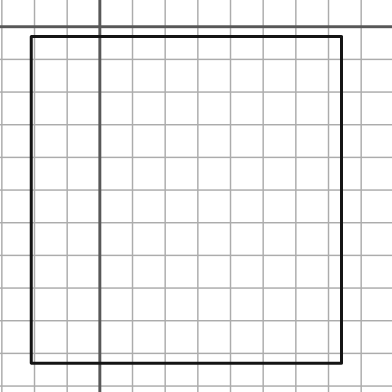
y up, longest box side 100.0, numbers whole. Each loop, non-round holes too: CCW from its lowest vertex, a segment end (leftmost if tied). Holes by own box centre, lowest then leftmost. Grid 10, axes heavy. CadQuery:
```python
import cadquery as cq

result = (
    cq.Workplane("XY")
    .moveTo(-21.0, -103.0)
    .lineTo(74.0, -103.0)
    .lineTo(74.0, -3.0)
    .lineTo(-21.0, -3.0)
    .close()
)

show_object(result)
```